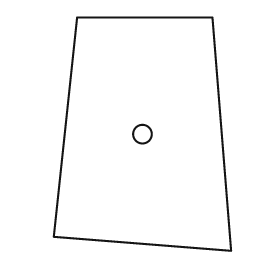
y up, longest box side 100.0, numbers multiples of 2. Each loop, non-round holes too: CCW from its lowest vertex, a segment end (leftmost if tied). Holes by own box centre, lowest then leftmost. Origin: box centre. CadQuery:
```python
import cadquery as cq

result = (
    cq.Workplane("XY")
    .moveTo(38.0, -50.0)
    .lineTo(30.0, 50.0)
    .lineTo(-28.0, 50.0)
    .lineTo(-38.0, -44.0)
    .close()
    .moveTo(0.0, 0.0)
    .circle(4.0)
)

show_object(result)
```